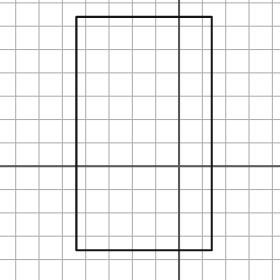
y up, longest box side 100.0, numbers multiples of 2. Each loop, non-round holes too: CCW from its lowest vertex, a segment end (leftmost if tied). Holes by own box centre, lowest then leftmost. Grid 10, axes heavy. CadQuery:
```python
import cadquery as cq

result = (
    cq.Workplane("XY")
    .moveTo(-44.0, -36.0)
    .lineTo(14.0, -36.0)
    .lineTo(14.0, 64.0)
    .lineTo(-44.0, 64.0)
    .close()
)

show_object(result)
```